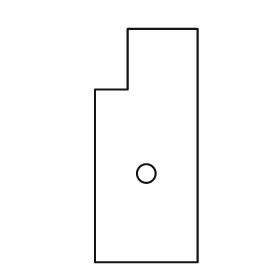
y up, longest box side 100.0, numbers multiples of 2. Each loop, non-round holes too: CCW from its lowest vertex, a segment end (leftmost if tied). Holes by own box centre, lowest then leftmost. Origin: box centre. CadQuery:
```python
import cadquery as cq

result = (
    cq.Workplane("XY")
    .moveTo(-22.0, -50.0)
    .lineTo(22.0, -50.0)
    .lineTo(22.0, 50.0)
    .lineTo(-8.0, 50.0)
    .lineTo(-8.0, 24.0)
    .lineTo(-22.0, 24.0)
    .close()
    .moveTo(0.0, -12.0)
    .circle(4.0)
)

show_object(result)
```